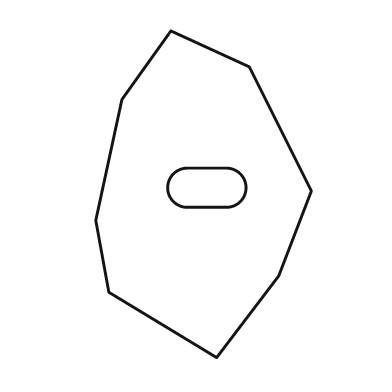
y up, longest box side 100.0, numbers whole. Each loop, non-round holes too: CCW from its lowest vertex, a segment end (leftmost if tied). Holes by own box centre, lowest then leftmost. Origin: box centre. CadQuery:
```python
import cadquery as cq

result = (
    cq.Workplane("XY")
    .moveTo(4.0, -50.0)
    .lineTo(23.0, -25.0)
    .lineTo(33.0, 1.0)
    .lineTo(14.0, 39.0)
    .lineTo(-10.0, 50.0)
    .lineTo(-25.0, 29.0)
    .lineTo(-33.0, -8.0)
    .lineTo(-29.0, -30.0)
    .close()
    .moveTo(-5.0, -4.0)
    .lineTo(7.0, -4.0)
    .threePointArc((13.0, 2.0), (7.0, 8.0))
    .lineTo(-5.0, 8.0)
    .threePointArc((-11.0, 2.0), (-5.0, -4.0))
    .close()
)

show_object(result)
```